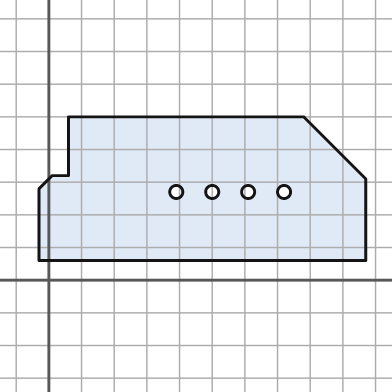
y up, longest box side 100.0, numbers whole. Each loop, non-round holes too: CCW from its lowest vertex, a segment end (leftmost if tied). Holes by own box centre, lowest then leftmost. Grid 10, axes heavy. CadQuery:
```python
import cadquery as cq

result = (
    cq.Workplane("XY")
    .moveTo(-3.0, 6.0)
    .lineTo(97.0, 6.0)
    .lineTo(97.0, 31.0)
    .lineTo(78.0, 50.0)
    .lineTo(6.0, 50.0)
    .lineTo(6.0, 32.0)
    .lineTo(1.0, 32.0)
    .lineTo(-3.0, 28.0)
    .close()
    .moveTo(39.0, 27.0)
    .circle(2.0)
    .moveTo(50.0, 27.0)
    .circle(2.0)
    .moveTo(61.0, 27.0)
    .circle(2.0)
    .moveTo(72.0, 27.0)
    .circle(2.0)
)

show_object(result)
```